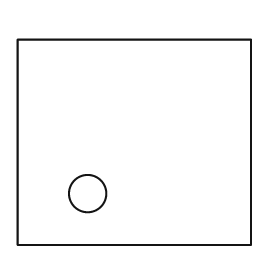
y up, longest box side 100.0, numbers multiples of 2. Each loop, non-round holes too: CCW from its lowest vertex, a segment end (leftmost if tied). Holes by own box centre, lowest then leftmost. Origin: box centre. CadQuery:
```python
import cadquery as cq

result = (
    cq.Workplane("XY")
    .moveTo(-50.0, -44.0)
    .lineTo(50.0, -44.0)
    .lineTo(50.0, 44.0)
    .lineTo(-50.0, 44.0)
    .close()
    .moveTo(-20.0, -22.0)
    .circle(8.0)
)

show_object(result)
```